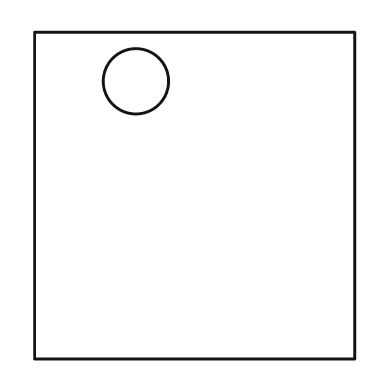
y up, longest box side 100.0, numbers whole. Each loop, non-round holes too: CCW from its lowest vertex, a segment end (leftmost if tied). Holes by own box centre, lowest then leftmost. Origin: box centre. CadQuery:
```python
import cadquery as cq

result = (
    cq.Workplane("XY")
    .moveTo(-49.0, -50.0)
    .lineTo(49.0, -50.0)
    .lineTo(49.0, 50.0)
    .lineTo(-49.0, 50.0)
    .close()
    .moveTo(-18.0, 35.0)
    .circle(10.0)
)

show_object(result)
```